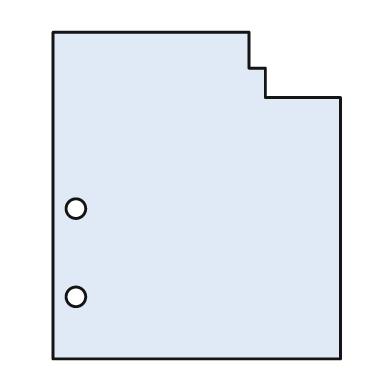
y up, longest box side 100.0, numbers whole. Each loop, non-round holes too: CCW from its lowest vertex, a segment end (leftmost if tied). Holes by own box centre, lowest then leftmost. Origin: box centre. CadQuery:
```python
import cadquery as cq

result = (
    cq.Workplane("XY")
    .moveTo(-44.0, -50.0)
    .lineTo(44.0, -50.0)
    .lineTo(44.0, 30.0)
    .lineTo(21.0, 30.0)
    .lineTo(21.0, 39.0)
    .lineTo(16.0, 39.0)
    .lineTo(16.0, 50.0)
    .lineTo(-44.0, 50.0)
    .close()
    .moveTo(-37.0, -31.0)
    .circle(3.0)
    .moveTo(-37.0, -4.0)
    .circle(3.0)
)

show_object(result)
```